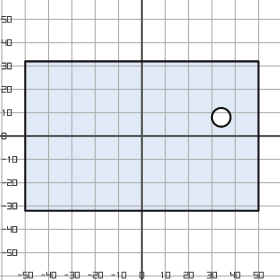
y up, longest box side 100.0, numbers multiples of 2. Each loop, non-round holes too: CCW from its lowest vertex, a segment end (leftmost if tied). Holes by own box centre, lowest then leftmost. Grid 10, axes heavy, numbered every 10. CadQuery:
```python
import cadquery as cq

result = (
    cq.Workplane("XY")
    .moveTo(-50.0, -32.0)
    .lineTo(50.0, -32.0)
    .lineTo(50.0, 32.0)
    .lineTo(-50.0, 32.0)
    .close()
    .moveTo(34.0, 8.0)
    .circle(4.0)
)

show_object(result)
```